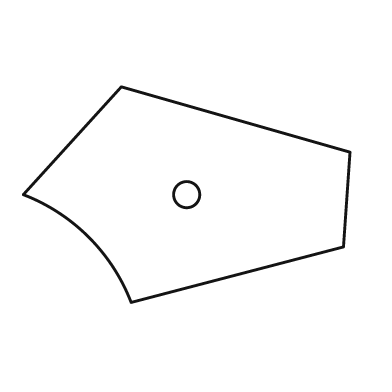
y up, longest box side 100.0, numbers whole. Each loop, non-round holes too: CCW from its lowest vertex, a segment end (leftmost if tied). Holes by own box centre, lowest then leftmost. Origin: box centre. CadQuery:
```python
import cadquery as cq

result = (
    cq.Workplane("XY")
    .moveTo(-17.0, -33.0)
    .lineTo(48.0, -16.0)
    .lineTo(50.0, 13.0)
    .lineTo(-20.0, 33.0)
    .lineTo(-50.0, 0.0)
    .threePointArc((-30.0, -13.0), (-17.0, -33.0))
    .close()
    .moveTo(0.0, 0.0)
    .circle(4.0)
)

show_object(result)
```